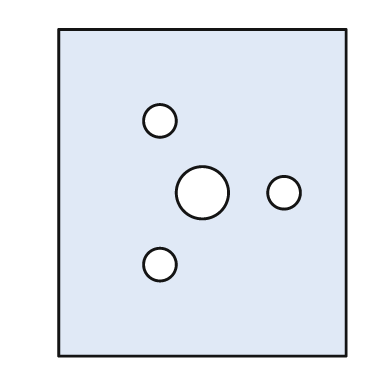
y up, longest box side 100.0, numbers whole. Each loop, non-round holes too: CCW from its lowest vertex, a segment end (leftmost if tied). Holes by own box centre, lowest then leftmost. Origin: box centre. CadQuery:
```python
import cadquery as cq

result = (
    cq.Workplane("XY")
    .moveTo(-44.0, -50.0)
    .lineTo(44.0, -50.0)
    .lineTo(44.0, 50.0)
    .lineTo(-44.0, 50.0)
    .close()
    .moveTo(-13.0, -22.0)
    .circle(5.0)
    .moveTo(0.0, 0.0)
    .circle(8.0)
    .moveTo(25.0, 0.0)
    .circle(5.0)
    .moveTo(-13.0, 22.0)
    .circle(5.0)
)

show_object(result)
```